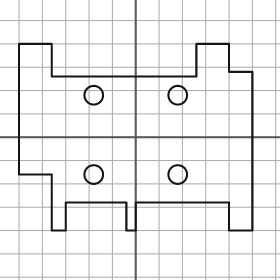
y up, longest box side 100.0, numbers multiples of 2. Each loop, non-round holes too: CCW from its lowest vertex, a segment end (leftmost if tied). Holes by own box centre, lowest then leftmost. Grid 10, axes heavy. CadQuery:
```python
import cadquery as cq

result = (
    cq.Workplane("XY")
    .moveTo(-36.0, -40.0)
    .lineTo(-30.0, -40.0)
    .lineTo(-30.0, -28.0)
    .lineTo(-4.0, -28.0)
    .lineTo(-4.0, -40.0)
    .lineTo(0.0, -40.0)
    .lineTo(0.0, -28.0)
    .lineTo(40.0, -28.0)
    .lineTo(40.0, -40.0)
    .lineTo(50.0, -40.0)
    .lineTo(50.0, 28.0)
    .lineTo(40.0, 28.0)
    .lineTo(40.0, 40.0)
    .lineTo(26.0, 40.0)
    .lineTo(26.0, 26.0)
    .lineTo(-36.0, 26.0)
    .lineTo(-36.0, 40.0)
    .lineTo(-50.0, 40.0)
    .lineTo(-50.0, -16.0)
    .lineTo(-36.0, -16.0)
    .close()
    .moveTo(-18.0, -16.0)
    .circle(4.0)
    .moveTo(18.0, -16.0)
    .circle(4.0)
    .moveTo(-18.0, 18.0)
    .circle(4.0)
    .moveTo(18.0, 18.0)
    .circle(4.0)
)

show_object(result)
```